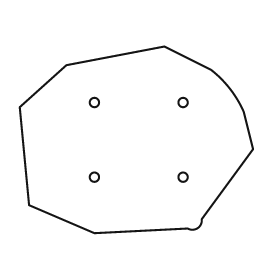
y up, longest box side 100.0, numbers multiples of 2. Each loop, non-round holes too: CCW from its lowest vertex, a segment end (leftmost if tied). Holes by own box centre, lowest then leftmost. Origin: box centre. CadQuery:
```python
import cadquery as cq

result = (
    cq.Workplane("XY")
    .moveTo(-18.0, -40.0)
    .lineTo(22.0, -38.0)
    .threePointArc((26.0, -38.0), (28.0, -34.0))
    .lineTo(50.0, -4.0)
    .lineTo(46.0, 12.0)
    .threePointArc((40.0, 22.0), (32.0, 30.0))
    .lineTo(12.0, 40.0)
    .lineTo(-30.0, 32.0)
    .lineTo(-50.0, 14.0)
    .lineTo(-46.0, -28.0)
    .close()
    .moveTo(-18.0, -16.0)
    .circle(2.0)
    .moveTo(20.0, -16.0)
    .circle(2.0)
    .moveTo(-18.0, 16.0)
    .circle(2.0)
    .moveTo(20.0, 16.0)
    .circle(2.0)
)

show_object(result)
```